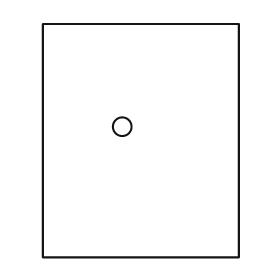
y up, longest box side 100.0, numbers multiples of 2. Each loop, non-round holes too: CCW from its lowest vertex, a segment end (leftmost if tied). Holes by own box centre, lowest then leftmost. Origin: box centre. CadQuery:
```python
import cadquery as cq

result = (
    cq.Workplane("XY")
    .moveTo(-42.0, -50.0)
    .lineTo(42.0, -50.0)
    .lineTo(42.0, 50.0)
    .lineTo(-42.0, 50.0)
    .close()
    .moveTo(-8.0, 6.0)
    .circle(4.0)
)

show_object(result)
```